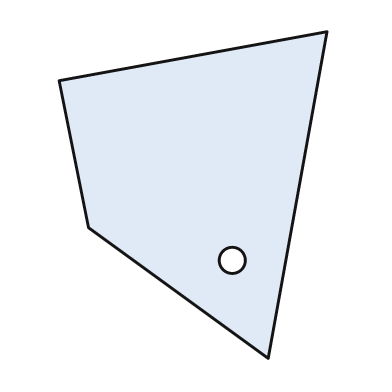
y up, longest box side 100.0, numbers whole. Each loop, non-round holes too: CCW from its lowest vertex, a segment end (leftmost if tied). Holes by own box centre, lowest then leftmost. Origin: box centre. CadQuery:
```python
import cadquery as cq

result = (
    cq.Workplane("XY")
    .moveTo(23.0, -50.0)
    .lineTo(41.0, 50.0)
    .lineTo(-41.0, 35.0)
    .lineTo(-32.0, -10.0)
    .close()
    .moveTo(12.0, -20.0)
    .circle(4.0)
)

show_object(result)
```